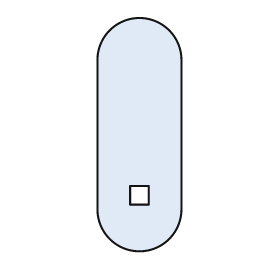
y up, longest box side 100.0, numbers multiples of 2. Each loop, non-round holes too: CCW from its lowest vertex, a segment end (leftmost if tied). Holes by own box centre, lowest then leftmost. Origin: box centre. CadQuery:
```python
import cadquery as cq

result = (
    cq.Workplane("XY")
    .moveTo(-18.0, -32.0)
    .threePointArc((0.0, -50.0), (18.0, -32.0))
    .lineTo(18.0, 32.0)
    .threePointArc((0.0, 50.0), (-18.0, 32.0))
    .close()
    .moveTo(-4.0, -30.0)
    .lineTo(4.0, -30.0)
    .lineTo(4.0, -22.0)
    .lineTo(-4.0, -22.0)
    .close()
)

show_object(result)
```